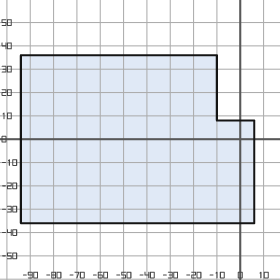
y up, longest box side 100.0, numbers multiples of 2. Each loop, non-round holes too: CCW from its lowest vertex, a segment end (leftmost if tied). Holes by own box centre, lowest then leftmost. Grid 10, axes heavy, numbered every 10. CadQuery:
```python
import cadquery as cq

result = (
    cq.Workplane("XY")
    .moveTo(-94.0, -36.0)
    .lineTo(6.0, -36.0)
    .lineTo(6.0, 8.0)
    .lineTo(-10.0, 8.0)
    .lineTo(-10.0, 36.0)
    .lineTo(-94.0, 36.0)
    .close()
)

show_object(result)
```